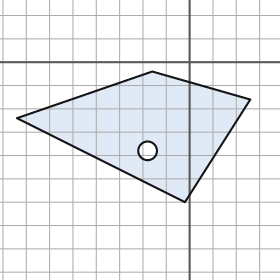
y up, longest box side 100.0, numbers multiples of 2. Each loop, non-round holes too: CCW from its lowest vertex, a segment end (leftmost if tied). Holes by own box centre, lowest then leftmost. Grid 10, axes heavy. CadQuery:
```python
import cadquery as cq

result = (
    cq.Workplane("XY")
    .moveTo(-2.0, -60.0)
    .lineTo(26.0, -16.0)
    .lineTo(-16.0, -4.0)
    .lineTo(-74.0, -24.0)
    .close()
    .moveTo(-18.0, -38.0)
    .circle(4.0)
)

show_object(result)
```